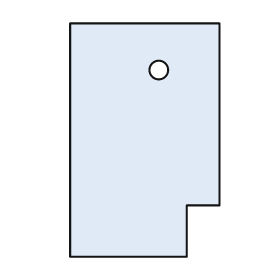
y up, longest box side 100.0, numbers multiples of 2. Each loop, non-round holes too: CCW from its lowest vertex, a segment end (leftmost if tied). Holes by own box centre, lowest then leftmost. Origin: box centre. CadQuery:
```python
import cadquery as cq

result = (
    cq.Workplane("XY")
    .moveTo(-32.0, -50.0)
    .lineTo(18.0, -50.0)
    .lineTo(18.0, -28.0)
    .lineTo(32.0, -28.0)
    .lineTo(32.0, 50.0)
    .lineTo(-32.0, 50.0)
    .close()
    .moveTo(6.0, 30.0)
    .circle(4.0)
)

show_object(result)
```